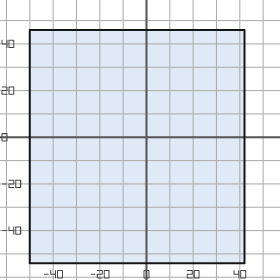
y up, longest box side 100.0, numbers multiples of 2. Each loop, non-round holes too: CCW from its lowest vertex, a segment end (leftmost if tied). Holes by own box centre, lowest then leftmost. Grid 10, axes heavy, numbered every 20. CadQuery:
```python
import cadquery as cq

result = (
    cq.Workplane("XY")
    .moveTo(-50.0, -54.0)
    .lineTo(42.0, -54.0)
    .lineTo(42.0, 46.0)
    .lineTo(-50.0, 46.0)
    .close()
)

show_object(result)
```